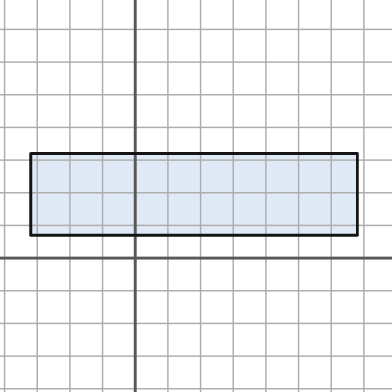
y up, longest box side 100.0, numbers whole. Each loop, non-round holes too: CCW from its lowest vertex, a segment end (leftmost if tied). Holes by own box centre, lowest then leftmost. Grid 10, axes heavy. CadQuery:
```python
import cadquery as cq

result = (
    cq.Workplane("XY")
    .moveTo(-32.0, 7.0)
    .lineTo(68.0, 7.0)
    .lineTo(68.0, 32.0)
    .lineTo(-32.0, 32.0)
    .close()
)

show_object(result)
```